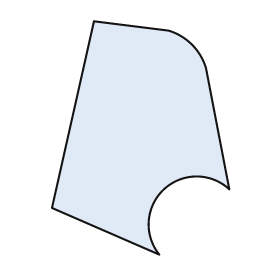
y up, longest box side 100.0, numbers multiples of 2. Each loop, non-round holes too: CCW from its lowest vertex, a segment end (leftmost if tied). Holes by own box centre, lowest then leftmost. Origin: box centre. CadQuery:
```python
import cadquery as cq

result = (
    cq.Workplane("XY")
    .moveTo(8.0, -50.0)
    .threePointArc((10.0, -22.0), (38.0, -22.0))
    .lineTo(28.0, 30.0)
    .threePointArc((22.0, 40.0), (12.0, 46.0))
    .lineTo(-20.0, 50.0)
    .lineTo(-38.0, -30.0)
    .close()
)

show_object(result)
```